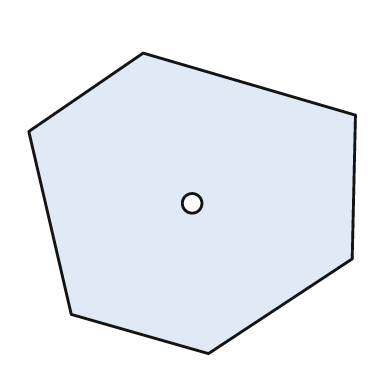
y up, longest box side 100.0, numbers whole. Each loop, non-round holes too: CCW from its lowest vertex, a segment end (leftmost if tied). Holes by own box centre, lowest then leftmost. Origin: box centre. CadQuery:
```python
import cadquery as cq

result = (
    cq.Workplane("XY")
    .moveTo(5.0, -46.0)
    .lineTo(49.0, -17.0)
    .lineTo(50.0, 27.0)
    .lineTo(-15.0, 46.0)
    .lineTo(-50.0, 22.0)
    .lineTo(-37.0, -34.0)
    .close()
    .moveTo(0.0, 0.0)
    .circle(3.0)
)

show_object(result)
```